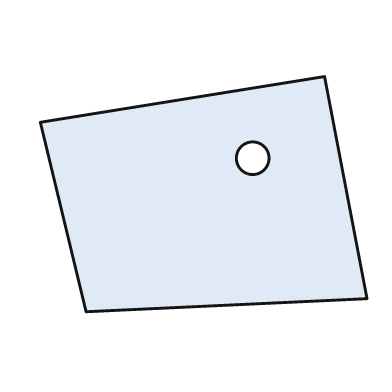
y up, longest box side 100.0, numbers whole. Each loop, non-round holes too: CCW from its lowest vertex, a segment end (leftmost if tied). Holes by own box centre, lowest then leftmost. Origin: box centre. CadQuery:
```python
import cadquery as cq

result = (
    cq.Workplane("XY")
    .moveTo(-36.0, -36.0)
    .lineTo(50.0, -32.0)
    .lineTo(37.0, 36.0)
    .lineTo(-50.0, 22.0)
    .close()
    .moveTo(15.0, 11.0)
    .circle(5.0)
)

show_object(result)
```